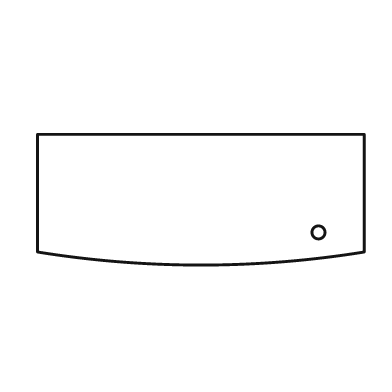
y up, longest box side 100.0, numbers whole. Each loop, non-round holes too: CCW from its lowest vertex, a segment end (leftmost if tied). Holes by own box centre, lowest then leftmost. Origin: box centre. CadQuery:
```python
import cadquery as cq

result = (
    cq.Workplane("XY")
    .moveTo(-50.0, -16.0)
    .threePointArc((0.0, -20.0), (50.0, -16.0))
    .lineTo(50.0, 20.0)
    .lineTo(-50.0, 20.0)
    .close()
    .moveTo(36.0, -10.0)
    .circle(2.0)
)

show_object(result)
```